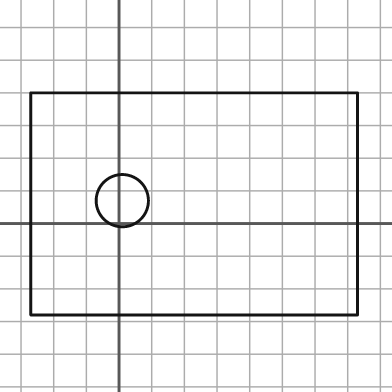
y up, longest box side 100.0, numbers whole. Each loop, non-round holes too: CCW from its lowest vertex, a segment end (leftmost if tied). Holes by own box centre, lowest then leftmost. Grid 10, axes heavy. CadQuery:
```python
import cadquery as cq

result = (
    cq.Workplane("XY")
    .moveTo(-27.0, -28.0)
    .lineTo(73.0, -28.0)
    .lineTo(73.0, 40.0)
    .lineTo(-27.0, 40.0)
    .close()
    .moveTo(1.0, 7.0)
    .circle(8.0)
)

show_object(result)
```